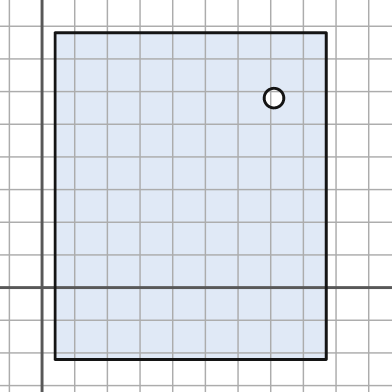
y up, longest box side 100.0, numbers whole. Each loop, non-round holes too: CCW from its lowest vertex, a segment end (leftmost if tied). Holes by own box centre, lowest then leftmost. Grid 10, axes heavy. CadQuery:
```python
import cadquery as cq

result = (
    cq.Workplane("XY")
    .moveTo(4.0, -22.0)
    .lineTo(87.0, -22.0)
    .lineTo(87.0, 78.0)
    .lineTo(4.0, 78.0)
    .close()
    .moveTo(71.0, 58.0)
    .circle(3.0)
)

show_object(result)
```